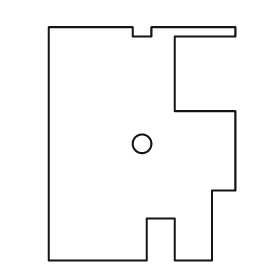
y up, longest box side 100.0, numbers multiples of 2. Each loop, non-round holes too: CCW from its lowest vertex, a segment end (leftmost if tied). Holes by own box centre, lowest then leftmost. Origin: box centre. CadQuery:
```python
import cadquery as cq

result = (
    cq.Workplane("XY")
    .moveTo(-40.0, -50.0)
    .lineTo(2.0, -50.0)
    .lineTo(2.0, -32.0)
    .lineTo(14.0, -32.0)
    .lineTo(14.0, -50.0)
    .lineTo(30.0, -50.0)
    .lineTo(30.0, -20.0)
    .lineTo(40.0, -20.0)
    .lineTo(40.0, 14.0)
    .lineTo(14.0, 14.0)
    .lineTo(14.0, 46.0)
    .lineTo(40.0, 46.0)
    .lineTo(40.0, 50.0)
    .lineTo(4.0, 50.0)
    .lineTo(4.0, 46.0)
    .lineTo(-4.0, 46.0)
    .lineTo(-4.0, 50.0)
    .lineTo(-40.0, 50.0)
    .close()
    .moveTo(0.0, 0.0)
    .circle(4.0)
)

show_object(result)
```